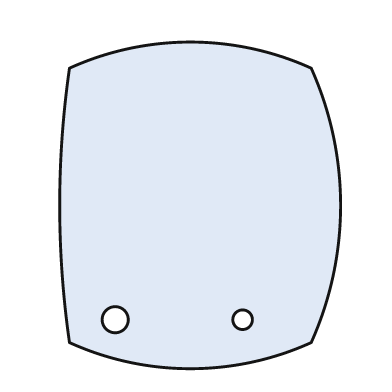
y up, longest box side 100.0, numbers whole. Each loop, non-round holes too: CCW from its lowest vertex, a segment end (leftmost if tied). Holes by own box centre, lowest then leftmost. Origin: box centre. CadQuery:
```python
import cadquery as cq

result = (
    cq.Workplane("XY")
    .moveTo(-40.0, -42.0)
    .threePointArc((-3.0, -50.0), (34.0, -42.0))
    .threePointArc((43.0, 0.0), (34.0, 42.0))
    .threePointArc((-3.0, 50.0), (-40.0, 42.0))
    .threePointArc((-43.0, 0.0), (-40.0, -42.0))
    .close()
    .moveTo(-26.0, -35.0)
    .circle(4.0)
    .moveTo(13.0, -35.0)
    .circle(3.0)
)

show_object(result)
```